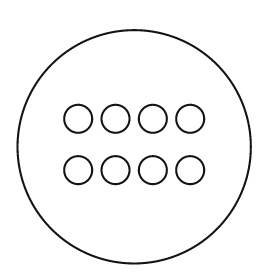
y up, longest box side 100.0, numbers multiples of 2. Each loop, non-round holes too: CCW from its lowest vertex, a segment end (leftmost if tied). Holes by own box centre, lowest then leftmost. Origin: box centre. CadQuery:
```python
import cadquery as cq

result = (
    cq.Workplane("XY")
    .moveTo(0.0, 0.0)
    .circle(50.0)
    .moveTo(-24.0, -10.0)
    .circle(6.0)
    .moveTo(-8.0, -10.0)
    .circle(6.0)
    .moveTo(8.0, -10.0)
    .circle(6.0)
    .moveTo(24.0, -10.0)
    .circle(6.0)
    .moveTo(-24.0, 12.0)
    .circle(6.0)
    .moveTo(-8.0, 12.0)
    .circle(6.0)
    .moveTo(8.0, 12.0)
    .circle(6.0)
    .moveTo(24.0, 12.0)
    .circle(6.0)
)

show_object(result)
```